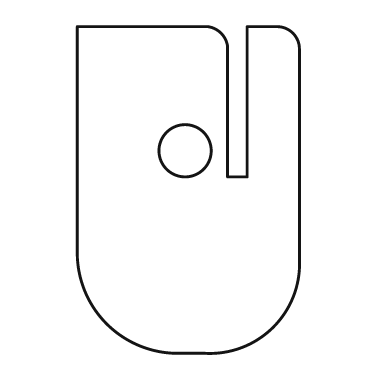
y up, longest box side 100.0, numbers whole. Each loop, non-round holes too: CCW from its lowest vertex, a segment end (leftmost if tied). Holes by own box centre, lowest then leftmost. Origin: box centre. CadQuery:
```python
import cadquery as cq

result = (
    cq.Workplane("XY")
    .moveTo(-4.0, -50.0)
    .lineTo(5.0, -50.0)
    .threePointArc((26.0, -42.0), (34.0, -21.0))
    .lineTo(34.0, 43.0)
    .threePointArc((32.0, 48.0), (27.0, 50.0))
    .lineTo(18.0, 50.0)
    .lineTo(18.0, 4.0)
    .lineTo(12.0, 4.0)
    .lineTo(12.0, 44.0)
    .threePointArc((10.0, 48.0), (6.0, 50.0))
    .lineTo(-34.0, 50.0)
    .lineTo(-34.0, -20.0)
    .threePointArc((-25.0, -41.0), (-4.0, -50.0))
    .close()
    .moveTo(-1.0, 12.0)
    .circle(8.0)
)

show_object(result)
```